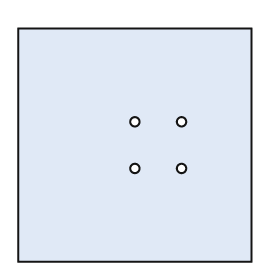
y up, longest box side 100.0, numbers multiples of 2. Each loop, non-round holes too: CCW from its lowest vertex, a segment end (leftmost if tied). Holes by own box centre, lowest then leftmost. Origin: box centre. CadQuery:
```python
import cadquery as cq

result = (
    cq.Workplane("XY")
    .moveTo(-50.0, -50.0)
    .lineTo(50.0, -50.0)
    .lineTo(50.0, 50.0)
    .lineTo(-50.0, 50.0)
    .close()
    .moveTo(0.0, -10.0)
    .circle(2.0)
    .moveTo(20.0, -10.0)
    .circle(2.0)
    .moveTo(0.0, 10.0)
    .circle(2.0)
    .moveTo(20.0, 10.0)
    .circle(2.0)
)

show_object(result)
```